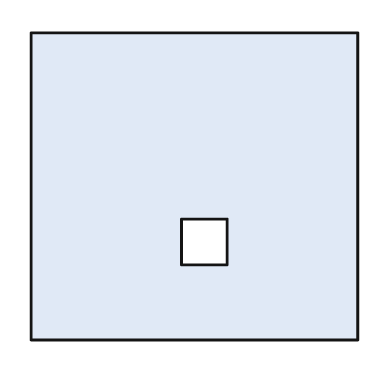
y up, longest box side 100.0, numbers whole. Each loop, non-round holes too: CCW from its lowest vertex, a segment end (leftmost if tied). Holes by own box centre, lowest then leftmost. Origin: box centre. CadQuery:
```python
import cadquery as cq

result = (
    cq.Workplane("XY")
    .moveTo(-50.0, -47.0)
    .lineTo(50.0, -47.0)
    .lineTo(50.0, 47.0)
    .lineTo(-50.0, 47.0)
    .close()
    .moveTo(-4.0, -24.0)
    .lineTo(10.0, -24.0)
    .lineTo(10.0, -10.0)
    .lineTo(-4.0, -10.0)
    .close()
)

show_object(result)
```